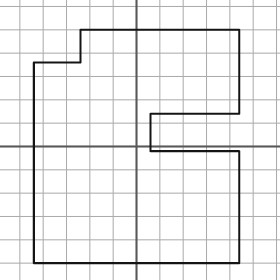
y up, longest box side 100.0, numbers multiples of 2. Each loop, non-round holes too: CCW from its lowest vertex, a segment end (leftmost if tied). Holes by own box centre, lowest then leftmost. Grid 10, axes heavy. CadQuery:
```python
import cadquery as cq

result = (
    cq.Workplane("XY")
    .moveTo(-44.0, -50.0)
    .lineTo(44.0, -50.0)
    .lineTo(44.0, -2.0)
    .lineTo(6.0, -2.0)
    .lineTo(6.0, 14.0)
    .lineTo(44.0, 14.0)
    .lineTo(44.0, 50.0)
    .lineTo(-24.0, 50.0)
    .lineTo(-24.0, 36.0)
    .lineTo(-44.0, 36.0)
    .close()
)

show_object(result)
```